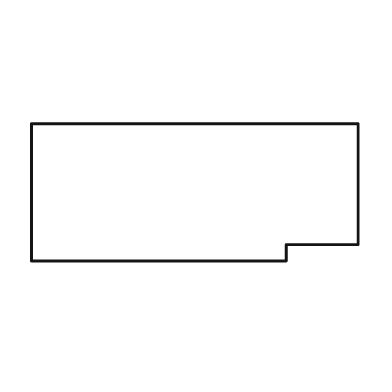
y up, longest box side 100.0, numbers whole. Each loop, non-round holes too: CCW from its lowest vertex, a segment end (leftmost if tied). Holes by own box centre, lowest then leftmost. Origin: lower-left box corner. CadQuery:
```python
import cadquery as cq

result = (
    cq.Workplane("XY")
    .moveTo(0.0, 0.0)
    .lineTo(78.0, 0.0)
    .lineTo(78.0, 5.0)
    .lineTo(100.0, 5.0)
    .lineTo(100.0, 42.0)
    .lineTo(0.0, 42.0)
    .close()
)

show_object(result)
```